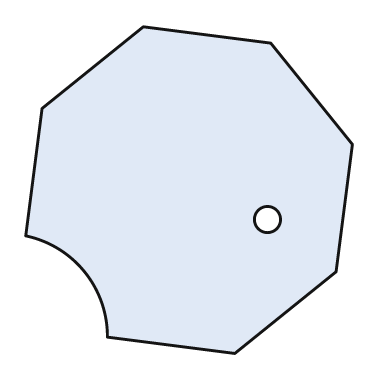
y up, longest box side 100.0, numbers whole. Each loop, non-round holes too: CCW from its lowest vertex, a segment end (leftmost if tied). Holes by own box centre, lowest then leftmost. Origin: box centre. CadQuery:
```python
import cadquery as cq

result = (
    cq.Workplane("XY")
    .moveTo(14.0, -50.0)
    .lineTo(45.0, -25.0)
    .lineTo(50.0, 14.0)
    .lineTo(25.0, 45.0)
    .lineTo(-14.0, 50.0)
    .lineTo(-45.0, 25.0)
    .lineTo(-50.0, -14.0)
    .threePointArc((-32.0, -25.0), (-25.0, -45.0))
    .close()
    .moveTo(24.0, -9.0)
    .circle(4.0)
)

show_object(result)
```